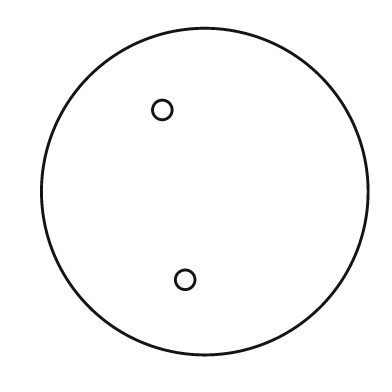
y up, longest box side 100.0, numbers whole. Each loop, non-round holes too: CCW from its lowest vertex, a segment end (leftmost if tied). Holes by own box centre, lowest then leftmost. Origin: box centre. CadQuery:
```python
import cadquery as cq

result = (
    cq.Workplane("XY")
    .moveTo(0.0, 0.0)
    .circle(50.0)
    .moveTo(-6.0, -27.0)
    .circle(3.0)
    .moveTo(-13.0, 25.0)
    .circle(3.0)
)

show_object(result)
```